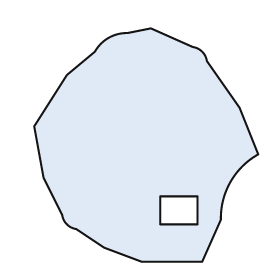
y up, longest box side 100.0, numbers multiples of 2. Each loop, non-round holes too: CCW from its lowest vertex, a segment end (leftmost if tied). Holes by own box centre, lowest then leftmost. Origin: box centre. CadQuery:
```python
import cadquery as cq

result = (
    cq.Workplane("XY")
    .moveTo(-2.0, -50.0)
    .lineTo(24.0, -50.0)
    .lineTo(32.0, -32.0)
    .threePointArc((36.0, -16.0), (48.0, -4.0))
    .lineTo(40.0, 16.0)
    .lineTo(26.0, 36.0)
    .threePointArc((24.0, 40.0), (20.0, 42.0))
    .lineTo(2.0, 50.0)
    .lineTo(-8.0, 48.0)
    .threePointArc((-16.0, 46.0), (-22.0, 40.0))
    .lineTo(-34.0, 30.0)
    .lineTo(-48.0, 8.0)
    .lineTo(-44.0, -14.0)
    .lineTo(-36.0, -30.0)
    .threePointArc((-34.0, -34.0), (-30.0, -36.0))
    .lineTo(-18.0, -44.0)
    .close()
    .moveTo(6.0, -34.0)
    .lineTo(22.0, -34.0)
    .lineTo(22.0, -22.0)
    .lineTo(6.0, -22.0)
    .close()
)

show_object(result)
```